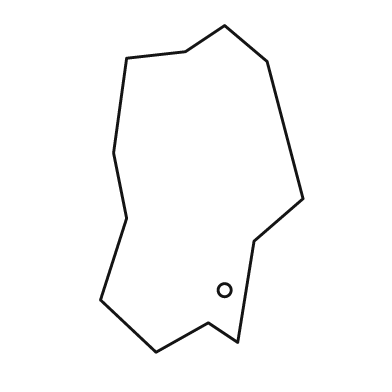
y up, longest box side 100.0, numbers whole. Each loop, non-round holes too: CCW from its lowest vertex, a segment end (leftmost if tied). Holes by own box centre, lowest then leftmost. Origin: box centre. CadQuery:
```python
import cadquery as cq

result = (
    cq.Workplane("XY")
    .moveTo(-14.0, -50.0)
    .lineTo(2.0, -41.0)
    .lineTo(11.0, -47.0)
    .lineTo(16.0, -16.0)
    .lineTo(31.0, -3.0)
    .lineTo(20.0, 39.0)
    .lineTo(7.0, 50.0)
    .lineTo(-5.0, 42.0)
    .lineTo(-23.0, 40.0)
    .lineTo(-27.0, 11.0)
    .lineTo(-23.0, -9.0)
    .lineTo(-31.0, -34.0)
    .close()
    .moveTo(7.0, -31.0)
    .circle(2.0)
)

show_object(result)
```